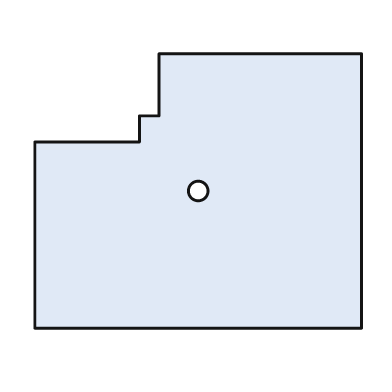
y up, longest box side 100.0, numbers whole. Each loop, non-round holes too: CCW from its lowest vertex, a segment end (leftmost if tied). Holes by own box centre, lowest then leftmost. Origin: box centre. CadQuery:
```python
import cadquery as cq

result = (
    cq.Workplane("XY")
    .moveTo(-50.0, -42.0)
    .lineTo(50.0, -42.0)
    .lineTo(50.0, 42.0)
    .lineTo(-12.0, 42.0)
    .lineTo(-12.0, 23.0)
    .lineTo(-18.0, 23.0)
    .lineTo(-18.0, 15.0)
    .lineTo(-50.0, 15.0)
    .close()
    .moveTo(0.0, 0.0)
    .circle(3.0)
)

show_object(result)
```